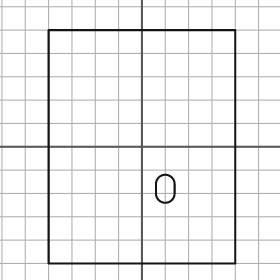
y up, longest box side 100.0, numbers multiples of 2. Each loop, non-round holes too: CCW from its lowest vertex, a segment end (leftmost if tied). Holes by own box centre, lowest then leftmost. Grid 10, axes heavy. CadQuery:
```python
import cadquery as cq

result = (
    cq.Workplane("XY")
    .moveTo(-40.0, -50.0)
    .lineTo(40.0, -50.0)
    .lineTo(40.0, 50.0)
    .lineTo(-40.0, 50.0)
    .close()
    .moveTo(6.0, -20.0)
    .threePointArc((10.0, -24.0), (14.0, -20.0))
    .lineTo(14.0, -16.0)
    .threePointArc((10.0, -12.0), (6.0, -16.0))
    .close()
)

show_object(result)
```